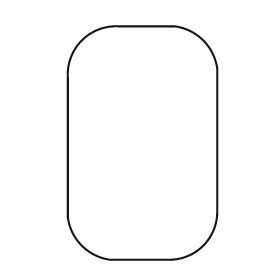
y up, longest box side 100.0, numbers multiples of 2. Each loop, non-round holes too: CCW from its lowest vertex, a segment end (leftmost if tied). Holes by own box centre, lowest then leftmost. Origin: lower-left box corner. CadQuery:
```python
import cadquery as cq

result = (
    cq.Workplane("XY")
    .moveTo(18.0, 0.0)
    .lineTo(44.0, 0.0)
    .threePointArc((58.0, 6.0), (64.0, 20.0))
    .lineTo(64.0, 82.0)
    .threePointArc((58.0, 94.0), (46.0, 100.0))
    .lineTo(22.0, 100.0)
    .threePointArc((6.0, 94.0), (0.0, 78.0))
    .lineTo(0.0, 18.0)
    .threePointArc((6.0, 6.0), (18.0, 0.0))
    .close()
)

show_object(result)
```